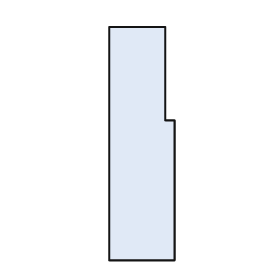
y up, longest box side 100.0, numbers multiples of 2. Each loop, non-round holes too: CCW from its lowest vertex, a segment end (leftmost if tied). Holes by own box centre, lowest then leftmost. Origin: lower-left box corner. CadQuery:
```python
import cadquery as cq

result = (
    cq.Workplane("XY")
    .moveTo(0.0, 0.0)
    .lineTo(28.0, 0.0)
    .lineTo(28.0, 60.0)
    .lineTo(24.0, 60.0)
    .lineTo(24.0, 100.0)
    .lineTo(0.0, 100.0)
    .close()
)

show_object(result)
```